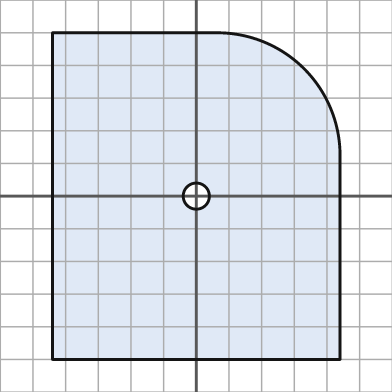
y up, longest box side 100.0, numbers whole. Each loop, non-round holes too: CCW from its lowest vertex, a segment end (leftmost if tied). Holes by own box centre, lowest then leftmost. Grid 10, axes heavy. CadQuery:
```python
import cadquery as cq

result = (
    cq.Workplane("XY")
    .moveTo(-44.0, -50.0)
    .lineTo(44.0, -50.0)
    .lineTo(44.0, 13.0)
    .threePointArc((33.0, 39.0), (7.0, 50.0))
    .lineTo(-44.0, 50.0)
    .close()
    .moveTo(0.0, 0.0)
    .circle(4.0)
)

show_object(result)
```